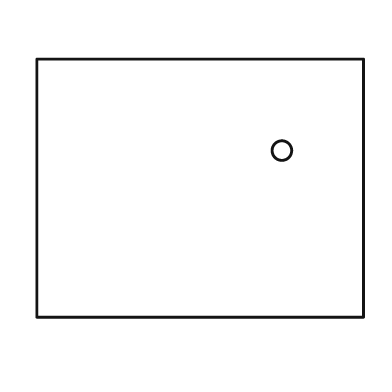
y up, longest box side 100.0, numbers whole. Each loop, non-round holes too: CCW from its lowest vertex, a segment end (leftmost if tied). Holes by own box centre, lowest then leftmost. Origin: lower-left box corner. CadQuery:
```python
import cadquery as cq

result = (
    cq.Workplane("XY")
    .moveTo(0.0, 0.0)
    .lineTo(100.0, 0.0)
    .lineTo(100.0, 79.0)
    .lineTo(0.0, 79.0)
    .close()
    .moveTo(75.0, 51.0)
    .circle(3.0)
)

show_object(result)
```